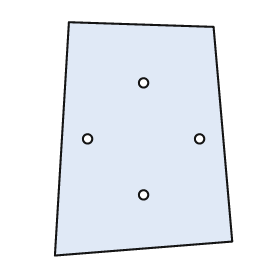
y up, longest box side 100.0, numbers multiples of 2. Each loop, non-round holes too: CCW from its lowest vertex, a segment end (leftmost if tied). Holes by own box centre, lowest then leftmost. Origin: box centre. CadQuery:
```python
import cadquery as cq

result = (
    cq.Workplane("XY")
    .moveTo(-38.0, -50.0)
    .lineTo(38.0, -44.0)
    .lineTo(30.0, 48.0)
    .lineTo(-32.0, 50.0)
    .close()
    .moveTo(0.0, -24.0)
    .circle(2.0)
    .moveTo(-24.0, 0.0)
    .circle(2.0)
    .moveTo(24.0, 0.0)
    .circle(2.0)
    .moveTo(0.0, 24.0)
    .circle(2.0)
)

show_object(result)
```